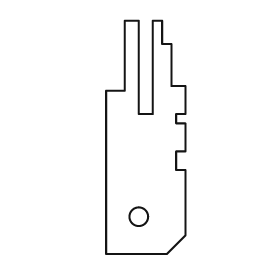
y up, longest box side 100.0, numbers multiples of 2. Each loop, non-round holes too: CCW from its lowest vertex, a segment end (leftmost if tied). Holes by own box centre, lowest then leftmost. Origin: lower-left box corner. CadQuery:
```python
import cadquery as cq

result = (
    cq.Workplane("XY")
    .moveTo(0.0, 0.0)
    .lineTo(26.0, 0.0)
    .lineTo(34.0, 8.0)
    .lineTo(34.0, 36.0)
    .lineTo(30.0, 36.0)
    .lineTo(30.0, 44.0)
    .lineTo(34.0, 44.0)
    .lineTo(34.0, 56.0)
    .lineTo(30.0, 56.0)
    .lineTo(30.0, 60.0)
    .lineTo(34.0, 60.0)
    .lineTo(34.0, 72.0)
    .lineTo(28.0, 72.0)
    .lineTo(28.0, 90.0)
    .lineTo(24.0, 90.0)
    .lineTo(24.0, 100.0)
    .lineTo(20.0, 100.0)
    .lineTo(20.0, 60.0)
    .lineTo(14.0, 60.0)
    .lineTo(14.0, 100.0)
    .lineTo(8.0, 100.0)
    .lineTo(8.0, 70.0)
    .lineTo(0.0, 70.0)
    .close()
    .moveTo(14.0, 16.0)
    .circle(4.0)
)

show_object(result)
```